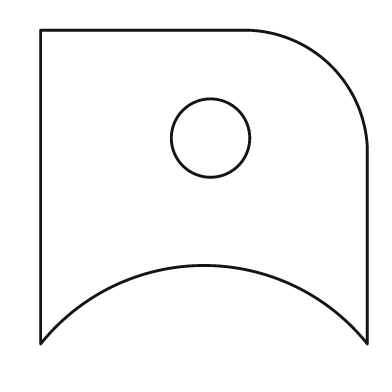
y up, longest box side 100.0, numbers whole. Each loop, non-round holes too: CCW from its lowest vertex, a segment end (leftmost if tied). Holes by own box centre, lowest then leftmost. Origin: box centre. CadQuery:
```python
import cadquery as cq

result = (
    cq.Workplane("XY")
    .moveTo(-50.0, -48.0)
    .threePointArc((0.0, -24.0), (50.0, -48.0))
    .lineTo(50.0, 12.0)
    .threePointArc((39.0, 37.0), (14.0, 48.0))
    .lineTo(-50.0, 48.0)
    .close()
    .moveTo(2.0, 15.0)
    .circle(12.0)
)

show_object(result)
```